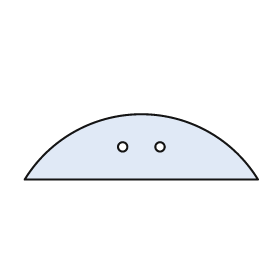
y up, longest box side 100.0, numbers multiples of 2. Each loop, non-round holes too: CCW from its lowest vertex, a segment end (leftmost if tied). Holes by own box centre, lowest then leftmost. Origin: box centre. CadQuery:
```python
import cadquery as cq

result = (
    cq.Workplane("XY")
    .moveTo(-50.0, -14.0)
    .lineTo(50.0, -14.0)
    .threePointArc((0.0, 14.0), (-50.0, -14.0))
    .close()
    .moveTo(-8.0, 0.0)
    .circle(2.0)
    .moveTo(8.0, 0.0)
    .circle(2.0)
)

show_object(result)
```